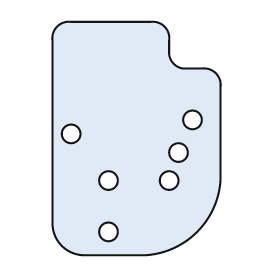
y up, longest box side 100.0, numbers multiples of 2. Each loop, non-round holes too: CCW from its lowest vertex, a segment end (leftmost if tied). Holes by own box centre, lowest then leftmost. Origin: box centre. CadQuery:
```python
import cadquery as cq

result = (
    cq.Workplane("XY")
    .moveTo(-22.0, -50.0)
    .lineTo(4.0, -50.0)
    .threePointArc((26.0, -40.0), (36.0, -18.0))
    .lineTo(36.0, 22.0)
    .threePointArc((34.0, 28.0), (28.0, 30.0))
    .lineTo(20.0, 30.0)
    .threePointArc((16.0, 32.0), (14.0, 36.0))
    .lineTo(14.0, 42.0)
    .threePointArc((12.0, 48.0), (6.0, 50.0))
    .lineTo(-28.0, 50.0)
    .threePointArc((-34.0, 48.0), (-36.0, 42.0))
    .lineTo(-36.0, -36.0)
    .threePointArc((-32.0, -46.0), (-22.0, -50.0))
    .close()
    .moveTo(-12.0, -40.0)
    .circle(4.0)
    .moveTo(-12.0, -18.0)
    .circle(4.0)
    .moveTo(14.0, -18.0)
    .circle(4.0)
    .moveTo(18.0, -6.0)
    .circle(4.0)
    .moveTo(-28.0, 2.0)
    .circle(4.0)
    .moveTo(24.0, 8.0)
    .circle(4.0)
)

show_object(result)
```